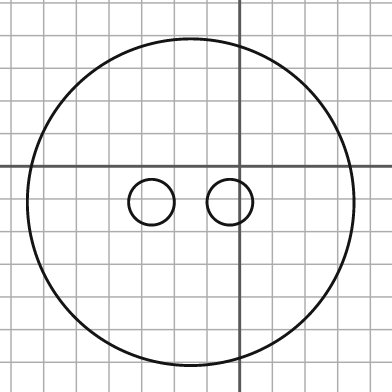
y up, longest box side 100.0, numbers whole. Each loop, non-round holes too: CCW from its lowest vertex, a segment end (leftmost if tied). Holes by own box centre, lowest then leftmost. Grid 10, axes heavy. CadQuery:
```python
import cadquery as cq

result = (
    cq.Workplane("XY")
    .moveTo(-15.0, -11.0)
    .circle(50.0)
    .moveTo(-27.0, -11.0)
    .circle(7.0)
    .moveTo(-3.0, -11.0)
    .circle(7.0)
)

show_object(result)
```